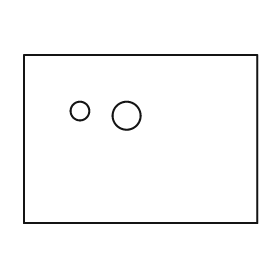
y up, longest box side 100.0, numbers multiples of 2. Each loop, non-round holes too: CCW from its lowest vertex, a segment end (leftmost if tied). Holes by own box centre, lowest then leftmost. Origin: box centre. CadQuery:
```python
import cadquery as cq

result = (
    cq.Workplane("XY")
    .moveTo(-50.0, -36.0)
    .lineTo(50.0, -36.0)
    .lineTo(50.0, 36.0)
    .lineTo(-50.0, 36.0)
    .close()
    .moveTo(-6.0, 10.0)
    .circle(6.0)
    .moveTo(-26.0, 12.0)
    .circle(4.0)
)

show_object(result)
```